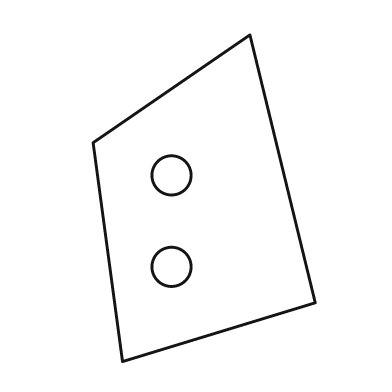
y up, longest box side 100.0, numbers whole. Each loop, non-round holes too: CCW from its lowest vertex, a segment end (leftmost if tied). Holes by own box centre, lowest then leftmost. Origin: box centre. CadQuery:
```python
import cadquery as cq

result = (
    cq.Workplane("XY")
    .moveTo(-25.0, -50.0)
    .lineTo(34.0, -32.0)
    .lineTo(14.0, 50.0)
    .lineTo(-34.0, 17.0)
    .close()
    .moveTo(-10.0, -21.0)
    .circle(6.0)
    .moveTo(-10.0, 7.0)
    .circle(6.0)
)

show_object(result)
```